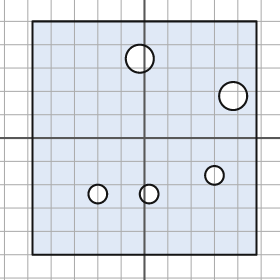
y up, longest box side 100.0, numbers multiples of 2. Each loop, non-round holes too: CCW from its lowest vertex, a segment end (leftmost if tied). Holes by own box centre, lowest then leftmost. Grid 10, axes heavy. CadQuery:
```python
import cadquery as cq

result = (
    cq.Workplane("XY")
    .moveTo(-48.0, -50.0)
    .lineTo(48.0, -50.0)
    .lineTo(48.0, 50.0)
    .lineTo(-48.0, 50.0)
    .close()
    .moveTo(-20.0, -24.0)
    .circle(4.0)
    .moveTo(2.0, -24.0)
    .circle(4.0)
    .moveTo(30.0, -16.0)
    .circle(4.0)
    .moveTo(38.0, 18.0)
    .circle(6.0)
    .moveTo(-2.0, 34.0)
    .circle(6.0)
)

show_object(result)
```